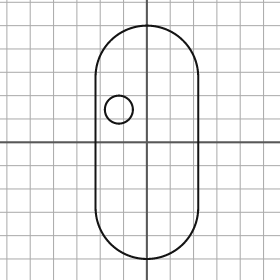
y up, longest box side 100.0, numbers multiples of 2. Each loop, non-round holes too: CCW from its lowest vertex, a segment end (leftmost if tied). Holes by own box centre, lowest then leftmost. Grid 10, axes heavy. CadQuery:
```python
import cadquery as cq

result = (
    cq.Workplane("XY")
    .moveTo(-22.0, -28.0)
    .threePointArc((0.0, -50.0), (22.0, -28.0))
    .lineTo(22.0, 28.0)
    .threePointArc((0.0, 50.0), (-22.0, 28.0))
    .close()
    .moveTo(-12.0, 14.0)
    .circle(6.0)
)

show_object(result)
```